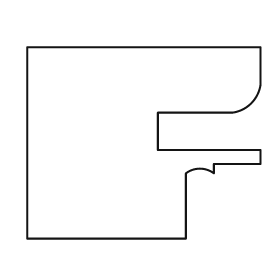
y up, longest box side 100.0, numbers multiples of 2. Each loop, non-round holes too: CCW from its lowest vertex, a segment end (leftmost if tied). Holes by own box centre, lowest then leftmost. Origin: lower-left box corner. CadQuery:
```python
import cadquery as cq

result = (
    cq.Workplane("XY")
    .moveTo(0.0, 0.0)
    .lineTo(68.0, 0.0)
    .lineTo(68.0, 28.0)
    .threePointArc((74.0, 30.0), (80.0, 28.0))
    .lineTo(80.0, 32.0)
    .lineTo(100.0, 32.0)
    .lineTo(100.0, 38.0)
    .lineTo(56.0, 38.0)
    .lineTo(56.0, 54.0)
    .lineTo(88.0, 54.0)
    .threePointArc((96.0, 58.0), (100.0, 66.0))
    .lineTo(100.0, 82.0)
    .lineTo(0.0, 82.0)
    .close()
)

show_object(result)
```